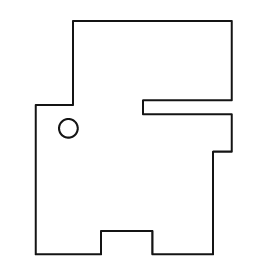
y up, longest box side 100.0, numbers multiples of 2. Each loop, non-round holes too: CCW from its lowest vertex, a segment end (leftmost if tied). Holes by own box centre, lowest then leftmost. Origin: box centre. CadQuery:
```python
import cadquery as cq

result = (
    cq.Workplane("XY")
    .moveTo(-42.0, -50.0)
    .lineTo(-14.0, -50.0)
    .lineTo(-14.0, -40.0)
    .lineTo(8.0, -40.0)
    .lineTo(8.0, -50.0)
    .lineTo(34.0, -50.0)
    .lineTo(34.0, -6.0)
    .lineTo(42.0, -6.0)
    .lineTo(42.0, 10.0)
    .lineTo(4.0, 10.0)
    .lineTo(4.0, 16.0)
    .lineTo(42.0, 16.0)
    .lineTo(42.0, 50.0)
    .lineTo(-26.0, 50.0)
    .lineTo(-26.0, 14.0)
    .lineTo(-42.0, 14.0)
    .close()
    .moveTo(-28.0, 4.0)
    .circle(4.0)
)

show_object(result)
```